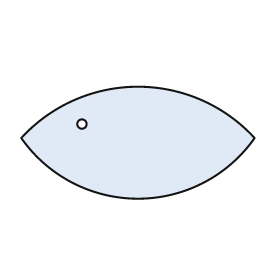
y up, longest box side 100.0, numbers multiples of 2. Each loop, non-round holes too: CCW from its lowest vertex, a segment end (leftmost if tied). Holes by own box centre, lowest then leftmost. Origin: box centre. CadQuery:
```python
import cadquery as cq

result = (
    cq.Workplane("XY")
    .moveTo(-50.0, 2.0)
    .threePointArc((0.0, -24.0), (50.0, 2.0))
    .threePointArc((0.0, 24.0), (-50.0, 2.0))
    .close()
    .moveTo(-24.0, 8.0)
    .circle(2.0)
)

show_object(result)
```